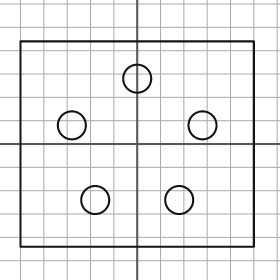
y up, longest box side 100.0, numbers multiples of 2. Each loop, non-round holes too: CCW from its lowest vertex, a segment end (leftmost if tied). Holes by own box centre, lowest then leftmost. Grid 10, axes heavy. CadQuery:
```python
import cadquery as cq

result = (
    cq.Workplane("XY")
    .moveTo(-50.0, -44.0)
    .lineTo(50.0, -44.0)
    .lineTo(50.0, 44.0)
    .lineTo(-50.0, 44.0)
    .close()
    .moveTo(-18.0, -24.0)
    .circle(6.0)
    .moveTo(18.0, -24.0)
    .circle(6.0)
    .moveTo(-28.0, 8.0)
    .circle(6.0)
    .moveTo(28.0, 8.0)
    .circle(6.0)
    .moveTo(0.0, 28.0)
    .circle(6.0)
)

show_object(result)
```